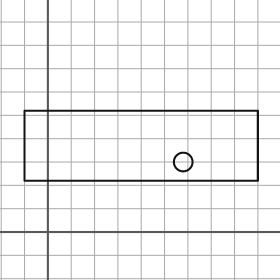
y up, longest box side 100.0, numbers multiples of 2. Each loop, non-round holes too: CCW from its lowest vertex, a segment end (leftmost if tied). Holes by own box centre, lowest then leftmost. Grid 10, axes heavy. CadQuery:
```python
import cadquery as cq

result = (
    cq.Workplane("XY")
    .moveTo(-10.0, 22.0)
    .lineTo(90.0, 22.0)
    .lineTo(90.0, 52.0)
    .lineTo(-10.0, 52.0)
    .close()
    .moveTo(58.0, 30.0)
    .circle(4.0)
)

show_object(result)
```